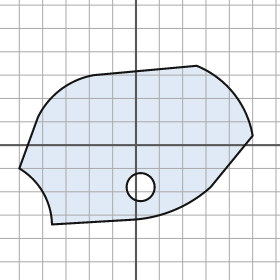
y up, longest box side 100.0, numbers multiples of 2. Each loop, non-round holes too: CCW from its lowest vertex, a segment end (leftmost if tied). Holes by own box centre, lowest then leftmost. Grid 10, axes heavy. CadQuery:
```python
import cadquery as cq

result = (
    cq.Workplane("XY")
    .moveTo(-36.0, -34.0)
    .lineTo(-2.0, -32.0)
    .threePointArc((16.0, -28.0), (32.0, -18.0))
    .lineTo(50.0, 4.0)
    .threePointArc((42.0, 22.0), (26.0, 34.0))
    .lineTo(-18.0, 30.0)
    .threePointArc((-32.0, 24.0), (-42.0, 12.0))
    .lineTo(-50.0, -10.0)
    .threePointArc((-40.0, -20.0), (-36.0, -34.0))
    .close()
    .moveTo(2.0, -18.0)
    .circle(6.0)
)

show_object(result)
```